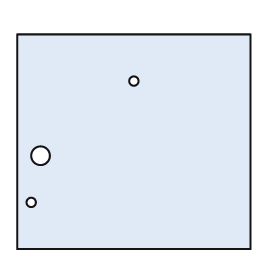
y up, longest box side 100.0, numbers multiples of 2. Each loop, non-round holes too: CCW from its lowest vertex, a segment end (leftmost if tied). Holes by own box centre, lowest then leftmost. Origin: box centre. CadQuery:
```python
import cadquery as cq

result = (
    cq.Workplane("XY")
    .moveTo(-50.0, -46.0)
    .lineTo(50.0, -46.0)
    .lineTo(50.0, 46.0)
    .lineTo(-50.0, 46.0)
    .close()
    .moveTo(-44.0, -26.0)
    .circle(2.0)
    .moveTo(-40.0, -6.0)
    .circle(4.0)
    .moveTo(0.0, 26.0)
    .circle(2.0)
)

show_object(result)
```